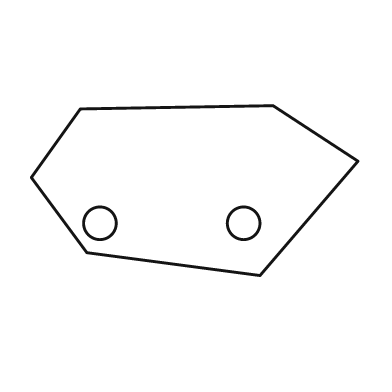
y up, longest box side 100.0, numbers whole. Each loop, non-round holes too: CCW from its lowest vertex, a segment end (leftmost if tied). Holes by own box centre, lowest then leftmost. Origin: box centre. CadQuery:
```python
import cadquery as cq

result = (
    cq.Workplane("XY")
    .moveTo(20.0, -26.0)
    .lineTo(50.0, 9.0)
    .lineTo(24.0, 26.0)
    .lineTo(-35.0, 25.0)
    .lineTo(-50.0, 4.0)
    .lineTo(-33.0, -19.0)
    .close()
    .moveTo(-29.0, -10.0)
    .circle(5.0)
    .moveTo(15.0, -10.0)
    .circle(5.0)
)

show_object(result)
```